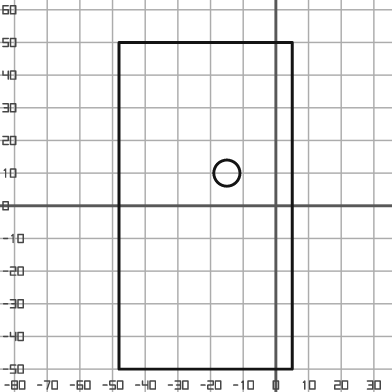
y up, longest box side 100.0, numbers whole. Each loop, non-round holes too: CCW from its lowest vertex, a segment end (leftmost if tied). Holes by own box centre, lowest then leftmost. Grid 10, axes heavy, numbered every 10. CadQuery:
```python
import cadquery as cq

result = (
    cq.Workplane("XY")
    .moveTo(-48.0, -50.0)
    .lineTo(5.0, -50.0)
    .lineTo(5.0, 50.0)
    .lineTo(-48.0, 50.0)
    .close()
    .moveTo(-15.0, 10.0)
    .circle(4.0)
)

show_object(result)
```